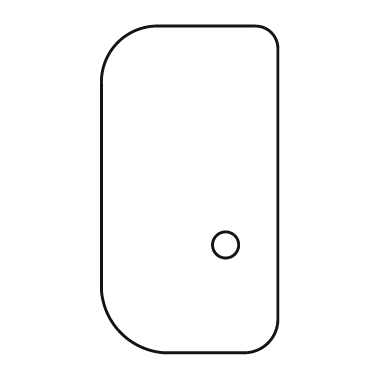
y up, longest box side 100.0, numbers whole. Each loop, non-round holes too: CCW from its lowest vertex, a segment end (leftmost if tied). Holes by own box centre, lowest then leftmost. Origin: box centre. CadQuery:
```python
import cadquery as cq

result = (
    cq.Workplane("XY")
    .moveTo(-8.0, -50.0)
    .lineTo(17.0, -50.0)
    .threePointArc((24.0, -47.0), (27.0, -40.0))
    .lineTo(27.0, 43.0)
    .threePointArc((25.0, 48.0), (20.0, 50.0))
    .lineTo(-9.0, 50.0)
    .threePointArc((-22.0, 45.0), (-27.0, 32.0))
    .lineTo(-27.0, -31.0)
    .threePointArc((-21.0, -44.0), (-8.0, -50.0))
    .close()
    .moveTo(11.0, -17.0)
    .circle(4.0)
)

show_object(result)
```